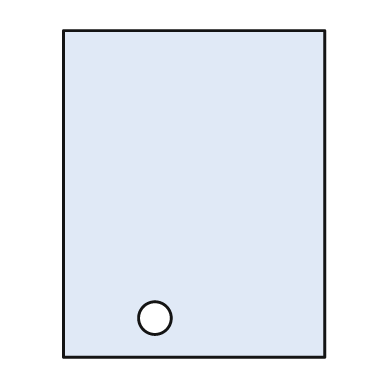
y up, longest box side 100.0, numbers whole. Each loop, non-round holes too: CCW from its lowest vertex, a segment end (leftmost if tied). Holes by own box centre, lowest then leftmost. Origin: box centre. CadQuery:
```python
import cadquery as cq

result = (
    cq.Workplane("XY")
    .moveTo(-40.0, -50.0)
    .lineTo(40.0, -50.0)
    .lineTo(40.0, 50.0)
    .lineTo(-40.0, 50.0)
    .close()
    .moveTo(-12.0, -38.0)
    .circle(5.0)
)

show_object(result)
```